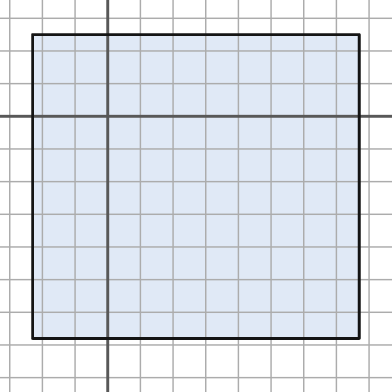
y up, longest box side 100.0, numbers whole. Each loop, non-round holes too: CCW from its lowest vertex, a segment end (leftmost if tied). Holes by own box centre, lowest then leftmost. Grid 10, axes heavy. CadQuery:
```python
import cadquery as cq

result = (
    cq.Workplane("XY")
    .moveTo(-23.0, -68.0)
    .lineTo(77.0, -68.0)
    .lineTo(77.0, 25.0)
    .lineTo(-23.0, 25.0)
    .close()
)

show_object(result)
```